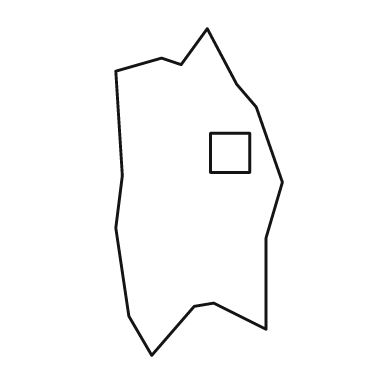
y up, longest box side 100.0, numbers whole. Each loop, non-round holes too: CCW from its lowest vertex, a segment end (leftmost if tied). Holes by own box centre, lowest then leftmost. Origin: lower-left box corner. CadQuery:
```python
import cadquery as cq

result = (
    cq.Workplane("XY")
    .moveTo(11.0, 0.0)
    .lineTo(24.0, 15.0)
    .lineTo(30.0, 16.0)
    .lineTo(46.0, 8.0)
    .lineTo(46.0, 36.0)
    .lineTo(51.0, 53.0)
    .lineTo(43.0, 76.0)
    .lineTo(37.0, 83.0)
    .lineTo(28.0, 100.0)
    .lineTo(20.0, 89.0)
    .lineTo(14.0, 91.0)
    .lineTo(0.0, 87.0)
    .lineTo(2.0, 55.0)
    .lineTo(0.0, 39.0)
    .lineTo(4.0, 12.0)
    .close()
    .moveTo(29.0, 56.0)
    .lineTo(41.0, 56.0)
    .lineTo(41.0, 68.0)
    .lineTo(29.0, 68.0)
    .close()
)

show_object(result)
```